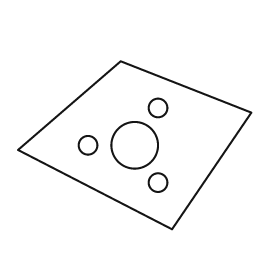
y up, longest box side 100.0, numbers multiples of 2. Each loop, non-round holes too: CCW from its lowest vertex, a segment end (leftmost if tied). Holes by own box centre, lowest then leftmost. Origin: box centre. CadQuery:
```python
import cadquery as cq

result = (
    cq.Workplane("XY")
    .moveTo(16.0, -36.0)
    .lineTo(50.0, 14.0)
    .lineTo(-6.0, 36.0)
    .lineTo(-50.0, -2.0)
    .close()
    .moveTo(10.0, -16.0)
    .circle(4.0)
    .moveTo(-20.0, 0.0)
    .circle(4.0)
    .moveTo(0.0, 0.0)
    .circle(10.0)
    .moveTo(10.0, 16.0)
    .circle(4.0)
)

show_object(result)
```